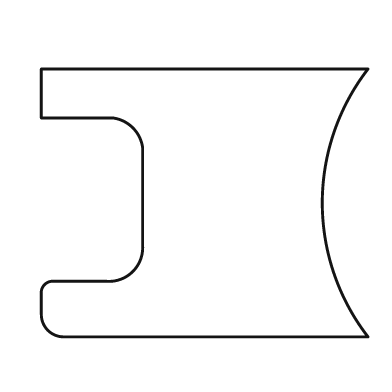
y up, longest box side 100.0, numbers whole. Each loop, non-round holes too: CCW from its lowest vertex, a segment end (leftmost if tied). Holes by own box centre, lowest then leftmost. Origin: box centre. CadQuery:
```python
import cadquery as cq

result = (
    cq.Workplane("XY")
    .moveTo(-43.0, -41.0)
    .lineTo(50.0, -41.0)
    .threePointArc((36.0, 0.0), (50.0, 41.0))
    .lineTo(-50.0, 41.0)
    .lineTo(-50.0, 26.0)
    .lineTo(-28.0, 26.0)
    .threePointArc((-22.0, 23.0), (-19.0, 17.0))
    .lineTo(-19.0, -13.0)
    .threePointArc((-22.0, -21.0), (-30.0, -24.0))
    .lineTo(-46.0, -24.0)
    .threePointArc((-49.0, -25.0), (-50.0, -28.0))
    .lineTo(-50.0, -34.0)
    .threePointArc((-48.0, -39.0), (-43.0, -41.0))
    .close()
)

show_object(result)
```